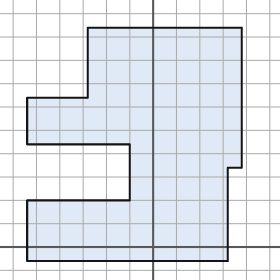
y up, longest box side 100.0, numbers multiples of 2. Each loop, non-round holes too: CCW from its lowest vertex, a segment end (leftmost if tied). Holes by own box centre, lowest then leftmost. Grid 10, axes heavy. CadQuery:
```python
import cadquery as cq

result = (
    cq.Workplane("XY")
    .moveTo(-54.0, -6.0)
    .lineTo(32.0, -6.0)
    .lineTo(32.0, 34.0)
    .lineTo(38.0, 34.0)
    .lineTo(38.0, 94.0)
    .lineTo(-28.0, 94.0)
    .lineTo(-28.0, 64.0)
    .lineTo(-54.0, 64.0)
    .lineTo(-54.0, 44.0)
    .lineTo(-10.0, 44.0)
    .lineTo(-10.0, 20.0)
    .lineTo(-54.0, 20.0)
    .close()
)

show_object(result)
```